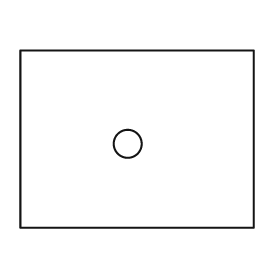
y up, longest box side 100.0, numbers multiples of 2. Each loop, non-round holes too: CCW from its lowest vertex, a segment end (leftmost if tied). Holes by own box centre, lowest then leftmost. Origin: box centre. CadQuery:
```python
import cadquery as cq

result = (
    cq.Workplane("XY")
    .moveTo(-50.0, -38.0)
    .lineTo(50.0, -38.0)
    .lineTo(50.0, 38.0)
    .lineTo(-50.0, 38.0)
    .close()
    .moveTo(-4.0, -2.0)
    .circle(6.0)
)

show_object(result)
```